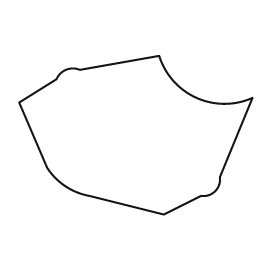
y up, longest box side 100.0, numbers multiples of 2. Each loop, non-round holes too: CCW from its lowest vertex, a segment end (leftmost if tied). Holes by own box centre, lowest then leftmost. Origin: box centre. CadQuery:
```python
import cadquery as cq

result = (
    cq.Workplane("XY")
    .moveTo(12.0, -34.0)
    .lineTo(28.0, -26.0)
    .threePointArc((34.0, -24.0), (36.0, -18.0))
    .lineTo(50.0, 16.0)
    .threePointArc((26.0, 16.0), (10.0, 34.0))
    .lineTo(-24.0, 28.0)
    .threePointArc((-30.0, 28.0), (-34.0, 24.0))
    .lineTo(-50.0, 14.0)
    .lineTo(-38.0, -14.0)
    .threePointArc((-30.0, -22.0), (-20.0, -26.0))
    .close()
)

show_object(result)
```